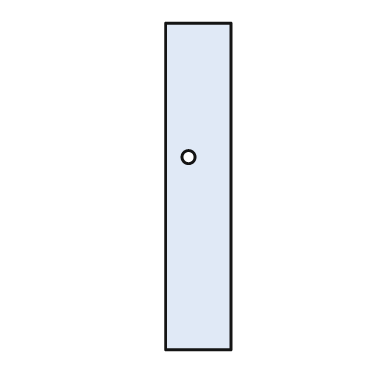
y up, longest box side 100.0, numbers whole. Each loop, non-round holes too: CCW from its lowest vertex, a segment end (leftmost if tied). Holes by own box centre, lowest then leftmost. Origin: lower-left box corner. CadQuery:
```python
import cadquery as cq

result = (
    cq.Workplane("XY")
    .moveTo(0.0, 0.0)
    .lineTo(20.0, 0.0)
    .lineTo(20.0, 100.0)
    .lineTo(0.0, 100.0)
    .close()
    .moveTo(7.0, 59.0)
    .circle(2.0)
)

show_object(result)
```